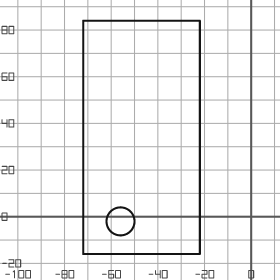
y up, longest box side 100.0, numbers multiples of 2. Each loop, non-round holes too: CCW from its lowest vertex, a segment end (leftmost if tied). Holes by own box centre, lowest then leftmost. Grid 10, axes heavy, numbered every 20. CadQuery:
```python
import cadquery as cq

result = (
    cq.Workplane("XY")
    .moveTo(-72.0, -16.0)
    .lineTo(-22.0, -16.0)
    .lineTo(-22.0, 84.0)
    .lineTo(-72.0, 84.0)
    .close()
    .moveTo(-56.0, -2.0)
    .circle(6.0)
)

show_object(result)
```